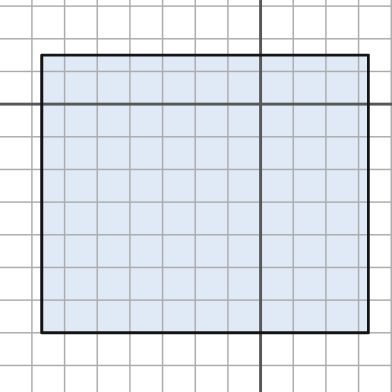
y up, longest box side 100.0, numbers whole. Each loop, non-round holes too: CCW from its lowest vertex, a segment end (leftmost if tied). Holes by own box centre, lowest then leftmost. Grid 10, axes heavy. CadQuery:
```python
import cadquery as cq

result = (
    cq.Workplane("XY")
    .moveTo(-67.0, -70.0)
    .lineTo(33.0, -70.0)
    .lineTo(33.0, 15.0)
    .lineTo(-67.0, 15.0)
    .close()
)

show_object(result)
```